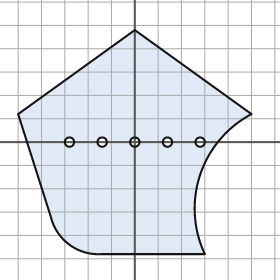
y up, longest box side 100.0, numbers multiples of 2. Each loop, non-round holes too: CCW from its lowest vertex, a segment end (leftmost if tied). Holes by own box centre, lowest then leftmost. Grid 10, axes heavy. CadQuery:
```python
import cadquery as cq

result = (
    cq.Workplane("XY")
    .moveTo(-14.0, -48.0)
    .lineTo(30.0, -48.0)
    .threePointArc((28.0, -14.0), (50.0, 12.0))
    .lineTo(0.0, 48.0)
    .lineTo(-50.0, 12.0)
    .lineTo(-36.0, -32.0)
    .threePointArc((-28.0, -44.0), (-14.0, -48.0))
    .close()
    .moveTo(-28.0, 0.0)
    .circle(2.0)
    .moveTo(-14.0, 0.0)
    .circle(2.0)
    .moveTo(0.0, 0.0)
    .circle(2.0)
    .moveTo(14.0, 0.0)
    .circle(2.0)
    .moveTo(28.0, 0.0)
    .circle(2.0)
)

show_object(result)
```